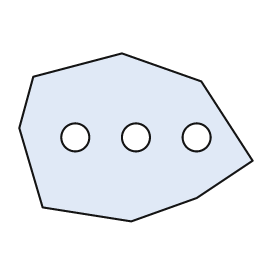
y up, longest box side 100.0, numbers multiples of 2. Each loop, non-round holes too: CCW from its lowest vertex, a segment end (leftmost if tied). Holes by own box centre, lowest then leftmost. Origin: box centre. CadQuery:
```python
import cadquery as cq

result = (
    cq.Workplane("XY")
    .moveTo(-2.0, -36.0)
    .lineTo(26.0, -26.0)
    .lineTo(50.0, -10.0)
    .lineTo(28.0, 24.0)
    .lineTo(-6.0, 36.0)
    .lineTo(-44.0, 26.0)
    .lineTo(-50.0, 4.0)
    .lineTo(-40.0, -30.0)
    .close()
    .moveTo(-26.0, 0.0)
    .circle(6.0)
    .moveTo(0.0, 0.0)
    .circle(6.0)
    .moveTo(26.0, 0.0)
    .circle(6.0)
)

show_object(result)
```